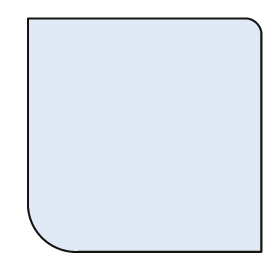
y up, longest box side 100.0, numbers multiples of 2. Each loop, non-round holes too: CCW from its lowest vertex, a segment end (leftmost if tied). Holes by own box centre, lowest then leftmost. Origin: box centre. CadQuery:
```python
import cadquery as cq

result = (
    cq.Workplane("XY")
    .moveTo(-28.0, -50.0)
    .lineTo(50.0, -50.0)
    .lineTo(50.0, 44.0)
    .threePointArc((48.0, 48.0), (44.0, 50.0))
    .lineTo(-50.0, 50.0)
    .lineTo(-50.0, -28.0)
    .threePointArc((-44.0, -44.0), (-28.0, -50.0))
    .close()
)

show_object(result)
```